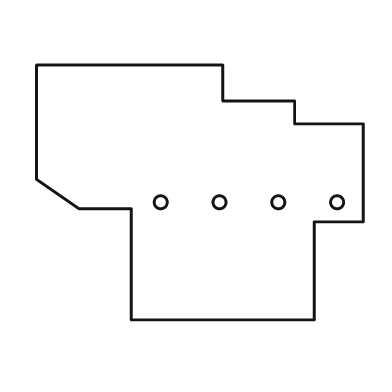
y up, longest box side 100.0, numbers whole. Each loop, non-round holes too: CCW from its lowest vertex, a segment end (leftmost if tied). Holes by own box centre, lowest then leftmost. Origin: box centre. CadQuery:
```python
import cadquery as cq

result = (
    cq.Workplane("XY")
    .moveTo(-21.0, -39.0)
    .lineTo(35.0, -39.0)
    .lineTo(35.0, -9.0)
    .lineTo(50.0, -9.0)
    .lineTo(50.0, 21.0)
    .lineTo(29.0, 21.0)
    .lineTo(29.0, 28.0)
    .lineTo(7.0, 28.0)
    .lineTo(7.0, 39.0)
    .lineTo(-50.0, 39.0)
    .lineTo(-50.0, 4.0)
    .lineTo(-37.0, -5.0)
    .lineTo(-21.0, -5.0)
    .close()
    .moveTo(-12.0, -3.0)
    .circle(2.0)
    .moveTo(6.0, -3.0)
    .circle(2.0)
    .moveTo(24.0, -3.0)
    .circle(2.0)
    .moveTo(42.0, -3.0)
    .circle(2.0)
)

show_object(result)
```